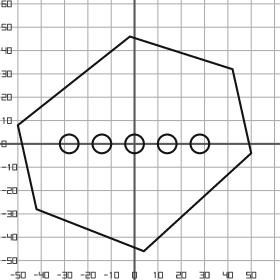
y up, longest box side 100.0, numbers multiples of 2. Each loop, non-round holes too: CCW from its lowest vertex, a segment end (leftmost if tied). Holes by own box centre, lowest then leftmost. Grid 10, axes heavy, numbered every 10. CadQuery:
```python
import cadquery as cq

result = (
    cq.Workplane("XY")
    .moveTo(4.0, -46.0)
    .lineTo(50.0, -4.0)
    .lineTo(42.0, 32.0)
    .lineTo(-2.0, 46.0)
    .lineTo(-50.0, 8.0)
    .lineTo(-42.0, -28.0)
    .close()
    .moveTo(-28.0, 0.0)
    .circle(4.0)
    .moveTo(-14.0, 0.0)
    .circle(4.0)
    .moveTo(0.0, 0.0)
    .circle(4.0)
    .moveTo(14.0, 0.0)
    .circle(4.0)
    .moveTo(28.0, 0.0)
    .circle(4.0)
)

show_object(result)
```